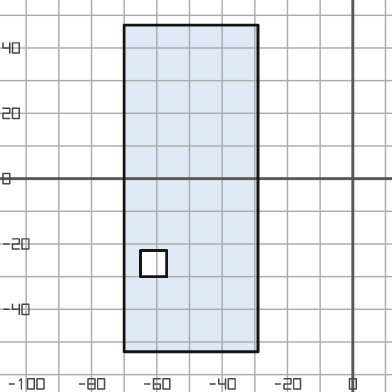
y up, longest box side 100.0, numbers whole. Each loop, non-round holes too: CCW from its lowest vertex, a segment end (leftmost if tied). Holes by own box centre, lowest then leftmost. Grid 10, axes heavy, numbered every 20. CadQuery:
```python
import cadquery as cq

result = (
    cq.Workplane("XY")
    .moveTo(-70.0, -53.0)
    .lineTo(-29.0, -53.0)
    .lineTo(-29.0, 47.0)
    .lineTo(-70.0, 47.0)
    .close()
    .moveTo(-65.0, -30.0)
    .lineTo(-57.0, -30.0)
    .lineTo(-57.0, -22.0)
    .lineTo(-65.0, -22.0)
    .close()
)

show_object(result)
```